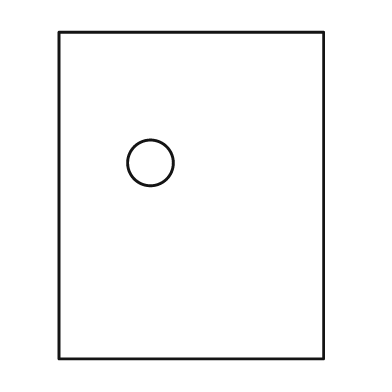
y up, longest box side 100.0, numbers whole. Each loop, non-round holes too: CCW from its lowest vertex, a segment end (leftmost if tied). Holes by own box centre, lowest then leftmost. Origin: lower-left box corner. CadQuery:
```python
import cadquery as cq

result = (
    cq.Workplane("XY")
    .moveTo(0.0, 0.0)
    .lineTo(81.0, 0.0)
    .lineTo(81.0, 100.0)
    .lineTo(0.0, 100.0)
    .close()
    .moveTo(28.0, 60.0)
    .circle(7.0)
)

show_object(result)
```